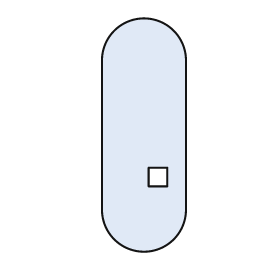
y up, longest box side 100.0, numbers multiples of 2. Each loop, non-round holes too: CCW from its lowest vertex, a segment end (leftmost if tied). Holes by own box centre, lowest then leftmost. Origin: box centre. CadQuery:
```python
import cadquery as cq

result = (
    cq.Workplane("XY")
    .moveTo(-18.0, -32.0)
    .threePointArc((0.0, -50.0), (18.0, -32.0))
    .lineTo(18.0, 32.0)
    .threePointArc((0.0, 50.0), (-18.0, 32.0))
    .close()
    .moveTo(2.0, -22.0)
    .lineTo(10.0, -22.0)
    .lineTo(10.0, -14.0)
    .lineTo(2.0, -14.0)
    .close()
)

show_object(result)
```